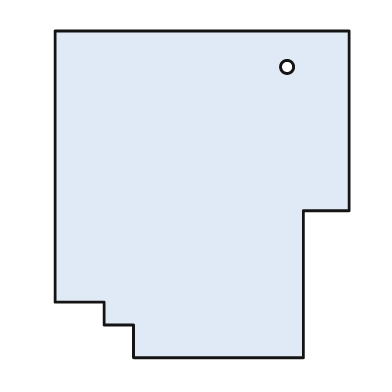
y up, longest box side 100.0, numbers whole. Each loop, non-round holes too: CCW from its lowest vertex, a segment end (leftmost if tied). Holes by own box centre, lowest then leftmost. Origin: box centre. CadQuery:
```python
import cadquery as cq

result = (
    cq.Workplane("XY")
    .moveTo(-21.0, -50.0)
    .lineTo(31.0, -50.0)
    .lineTo(31.0, -5.0)
    .lineTo(45.0, -5.0)
    .lineTo(45.0, 50.0)
    .lineTo(-45.0, 50.0)
    .lineTo(-45.0, -33.0)
    .lineTo(-30.0, -33.0)
    .lineTo(-30.0, -40.0)
    .lineTo(-21.0, -40.0)
    .close()
    .moveTo(26.0, 39.0)
    .circle(2.0)
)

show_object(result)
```